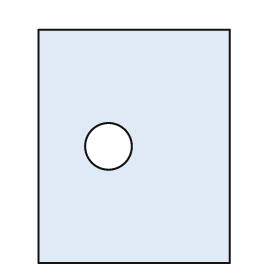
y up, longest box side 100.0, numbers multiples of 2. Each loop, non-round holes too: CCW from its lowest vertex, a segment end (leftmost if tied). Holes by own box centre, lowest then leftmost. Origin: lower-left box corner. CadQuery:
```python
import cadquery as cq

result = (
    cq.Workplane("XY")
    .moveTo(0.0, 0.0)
    .lineTo(82.0, 0.0)
    .lineTo(82.0, 100.0)
    .lineTo(0.0, 100.0)
    .close()
    .moveTo(30.0, 50.0)
    .circle(10.0)
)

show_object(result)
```